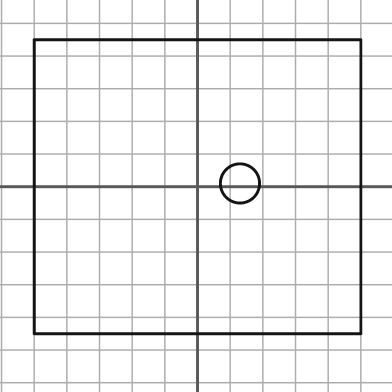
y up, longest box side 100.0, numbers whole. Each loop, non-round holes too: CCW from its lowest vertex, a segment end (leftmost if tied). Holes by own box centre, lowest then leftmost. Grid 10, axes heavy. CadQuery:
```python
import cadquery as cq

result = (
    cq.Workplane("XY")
    .moveTo(-50.0, -45.0)
    .lineTo(50.0, -45.0)
    .lineTo(50.0, 45.0)
    .lineTo(-50.0, 45.0)
    .close()
    .moveTo(13.0, 1.0)
    .circle(6.0)
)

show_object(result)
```